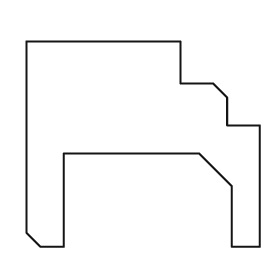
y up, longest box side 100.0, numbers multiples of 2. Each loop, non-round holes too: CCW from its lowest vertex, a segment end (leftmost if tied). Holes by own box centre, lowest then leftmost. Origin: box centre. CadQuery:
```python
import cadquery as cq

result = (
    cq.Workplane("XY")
    .moveTo(-44.0, -44.0)
    .lineTo(-34.0, -44.0)
    .lineTo(-34.0, -4.0)
    .lineTo(24.0, -4.0)
    .lineTo(38.0, -18.0)
    .lineTo(38.0, -44.0)
    .lineTo(50.0, -44.0)
    .lineTo(50.0, 8.0)
    .lineTo(36.0, 8.0)
    .lineTo(36.0, 20.0)
    .lineTo(30.0, 26.0)
    .lineTo(16.0, 26.0)
    .lineTo(16.0, 44.0)
    .lineTo(-50.0, 44.0)
    .lineTo(-50.0, -38.0)
    .close()
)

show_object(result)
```